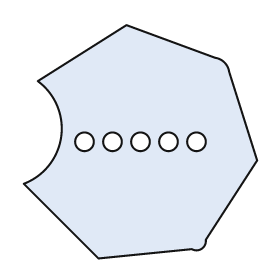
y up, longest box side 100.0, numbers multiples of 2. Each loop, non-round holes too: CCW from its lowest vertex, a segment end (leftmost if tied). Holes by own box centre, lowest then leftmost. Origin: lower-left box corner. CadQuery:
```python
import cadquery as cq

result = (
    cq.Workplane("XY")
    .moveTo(32.0, 0.0)
    .lineTo(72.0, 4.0)
    .threePointArc((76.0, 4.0), (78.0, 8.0))
    .lineTo(100.0, 42.0)
    .lineTo(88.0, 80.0)
    .threePointArc((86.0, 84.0), (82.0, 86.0))
    .lineTo(44.0, 100.0)
    .lineTo(6.0, 76.0)
    .threePointArc((16.0, 52.0), (0.0, 32.0))
    .close()
    .moveTo(26.0, 50.0)
    .circle(4.0)
    .moveTo(38.0, 50.0)
    .circle(4.0)
    .moveTo(50.0, 50.0)
    .circle(4.0)
    .moveTo(62.0, 50.0)
    .circle(4.0)
    .moveTo(74.0, 50.0)
    .circle(4.0)
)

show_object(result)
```